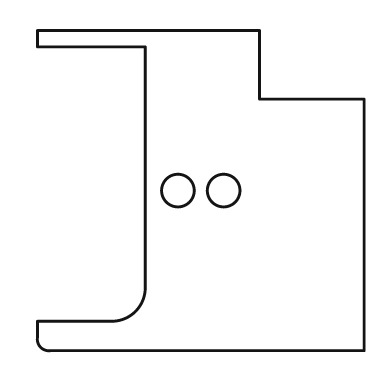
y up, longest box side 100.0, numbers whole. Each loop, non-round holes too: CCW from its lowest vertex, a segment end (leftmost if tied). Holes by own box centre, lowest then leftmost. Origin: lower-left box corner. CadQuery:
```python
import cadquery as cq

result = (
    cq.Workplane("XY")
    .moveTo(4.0, 0.0)
    .lineTo(100.0, 0.0)
    .lineTo(100.0, 77.0)
    .lineTo(68.0, 77.0)
    .lineTo(68.0, 98.0)
    .lineTo(0.0, 98.0)
    .lineTo(0.0, 93.0)
    .lineTo(33.0, 93.0)
    .lineTo(33.0, 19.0)
    .threePointArc((30.0, 12.0), (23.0, 9.0))
    .lineTo(0.0, 9.0)
    .lineTo(0.0, 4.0)
    .threePointArc((1.0, 1.0), (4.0, 0.0))
    .close()
    .moveTo(43.0, 49.0)
    .circle(5.0)
    .moveTo(57.0, 49.0)
    .circle(5.0)
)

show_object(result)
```